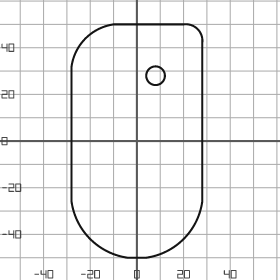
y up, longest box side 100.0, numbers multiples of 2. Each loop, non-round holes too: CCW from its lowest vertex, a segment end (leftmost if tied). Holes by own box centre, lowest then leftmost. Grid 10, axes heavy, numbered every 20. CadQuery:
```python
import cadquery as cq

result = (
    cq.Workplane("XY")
    .moveTo(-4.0, -50.0)
    .lineTo(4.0, -50.0)
    .threePointArc((20.0, -42.0), (28.0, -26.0))
    .lineTo(28.0, 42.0)
    .threePointArc((26.0, 48.0), (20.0, 50.0))
    .lineTo(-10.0, 50.0)
    .threePointArc((-22.0, 44.0), (-28.0, 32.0))
    .lineTo(-28.0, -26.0)
    .threePointArc((-20.0, -42.0), (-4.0, -50.0))
    .close()
    .moveTo(8.0, 28.0)
    .circle(4.0)
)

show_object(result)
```